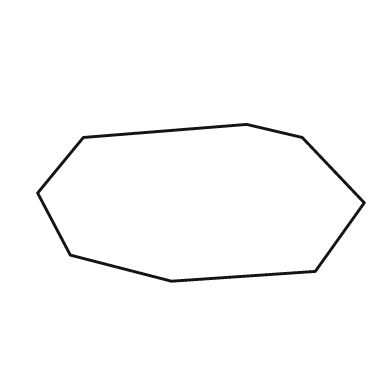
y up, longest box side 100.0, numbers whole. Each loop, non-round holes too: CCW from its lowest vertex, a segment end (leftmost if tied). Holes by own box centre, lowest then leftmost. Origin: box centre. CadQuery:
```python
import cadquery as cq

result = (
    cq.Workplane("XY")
    .moveTo(-9.0, -24.0)
    .lineTo(35.0, -21.0)
    .lineTo(50.0, 0.0)
    .lineTo(31.0, 20.0)
    .lineTo(14.0, 24.0)
    .lineTo(-36.0, 20.0)
    .lineTo(-50.0, 3.0)
    .lineTo(-40.0, -16.0)
    .close()
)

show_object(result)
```